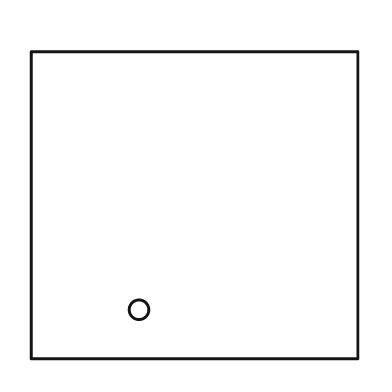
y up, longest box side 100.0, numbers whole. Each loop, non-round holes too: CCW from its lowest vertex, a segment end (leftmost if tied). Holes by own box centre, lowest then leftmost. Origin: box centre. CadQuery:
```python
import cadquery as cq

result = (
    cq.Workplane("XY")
    .moveTo(-50.0, -47.0)
    .lineTo(50.0, -47.0)
    .lineTo(50.0, 47.0)
    .lineTo(-50.0, 47.0)
    .close()
    .moveTo(-17.0, -32.0)
    .circle(3.0)
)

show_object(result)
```